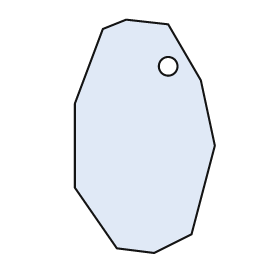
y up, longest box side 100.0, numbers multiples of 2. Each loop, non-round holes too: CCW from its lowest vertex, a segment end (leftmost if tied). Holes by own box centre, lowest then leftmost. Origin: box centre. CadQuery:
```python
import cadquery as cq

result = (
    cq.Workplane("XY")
    .moveTo(4.0, -50.0)
    .lineTo(20.0, -42.0)
    .lineTo(30.0, -4.0)
    .lineTo(24.0, 24.0)
    .lineTo(10.0, 48.0)
    .lineTo(-8.0, 50.0)
    .lineTo(-18.0, 46.0)
    .lineTo(-30.0, 14.0)
    .lineTo(-30.0, -22.0)
    .lineTo(-12.0, -48.0)
    .close()
    .moveTo(10.0, 30.0)
    .circle(4.0)
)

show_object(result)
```